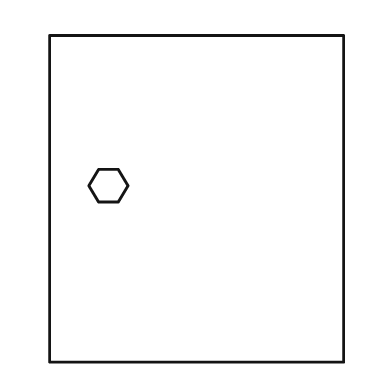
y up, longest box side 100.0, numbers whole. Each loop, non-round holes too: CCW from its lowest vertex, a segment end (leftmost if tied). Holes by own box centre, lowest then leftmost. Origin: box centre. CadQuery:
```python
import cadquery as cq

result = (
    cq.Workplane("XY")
    .moveTo(-45.0, -50.0)
    .lineTo(45.0, -50.0)
    .lineTo(45.0, 50.0)
    .lineTo(-45.0, 50.0)
    .close()
    .moveTo(-30.0, -1.0)
    .lineTo(-24.0, -1.0)
    .lineTo(-21.0, 4.0)
    .lineTo(-24.0, 9.0)
    .lineTo(-30.0, 9.0)
    .lineTo(-33.0, 4.0)
    .close()
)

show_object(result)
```